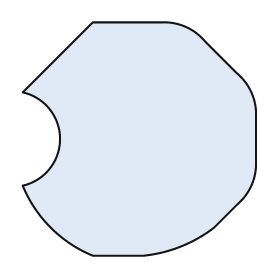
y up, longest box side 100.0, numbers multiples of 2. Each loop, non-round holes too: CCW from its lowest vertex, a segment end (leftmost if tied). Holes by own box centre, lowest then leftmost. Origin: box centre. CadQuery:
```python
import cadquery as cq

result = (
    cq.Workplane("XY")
    .moveTo(-20.0, -50.0)
    .lineTo(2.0, -50.0)
    .threePointArc((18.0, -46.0), (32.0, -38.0))
    .lineTo(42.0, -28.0)
    .threePointArc((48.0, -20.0), (50.0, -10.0))
    .lineTo(50.0, 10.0)
    .threePointArc((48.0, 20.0), (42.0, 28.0))
    .lineTo(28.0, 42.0)
    .threePointArc((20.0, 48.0), (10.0, 50.0))
    .lineTo(-20.0, 50.0)
    .lineTo(-50.0, 20.0)
    .threePointArc((-34.0, 0.0), (-50.0, -20.0))
    .threePointArc((-38.0, -38.0), (-20.0, -50.0))
    .close()
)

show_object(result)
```